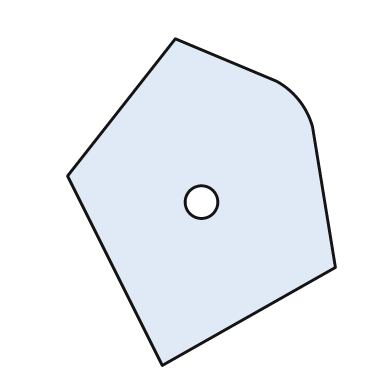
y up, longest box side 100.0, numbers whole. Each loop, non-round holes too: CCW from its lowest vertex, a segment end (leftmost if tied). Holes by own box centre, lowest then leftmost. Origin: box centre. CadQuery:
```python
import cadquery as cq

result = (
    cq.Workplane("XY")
    .moveTo(-12.0, -50.0)
    .lineTo(41.0, -20.0)
    .lineTo(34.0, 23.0)
    .threePointArc((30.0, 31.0), (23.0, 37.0))
    .lineTo(-8.0, 50.0)
    .lineTo(-41.0, 8.0)
    .close()
    .moveTo(0.0, 0.0)
    .circle(5.0)
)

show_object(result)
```